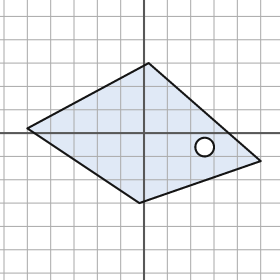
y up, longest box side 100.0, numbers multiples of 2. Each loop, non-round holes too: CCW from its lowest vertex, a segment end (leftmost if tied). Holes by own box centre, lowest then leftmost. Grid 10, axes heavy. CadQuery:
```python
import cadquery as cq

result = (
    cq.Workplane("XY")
    .moveTo(-2.0, -30.0)
    .lineTo(50.0, -12.0)
    .lineTo(2.0, 30.0)
    .lineTo(-50.0, 2.0)
    .close()
    .moveTo(26.0, -6.0)
    .circle(4.0)
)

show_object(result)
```